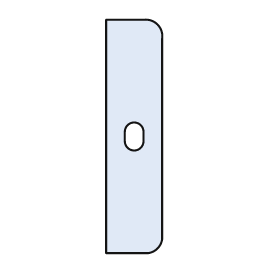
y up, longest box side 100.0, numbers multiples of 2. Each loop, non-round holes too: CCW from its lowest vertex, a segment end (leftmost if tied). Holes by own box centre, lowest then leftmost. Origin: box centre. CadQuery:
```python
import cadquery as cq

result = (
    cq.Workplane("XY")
    .moveTo(-12.0, -50.0)
    .lineTo(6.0, -50.0)
    .threePointArc((10.0, -48.0), (12.0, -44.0))
    .lineTo(12.0, 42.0)
    .threePointArc((10.0, 48.0), (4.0, 50.0))
    .lineTo(-12.0, 50.0)
    .close()
    .moveTo(-4.0, -2.0)
    .threePointArc((0.0, -6.0), (4.0, -2.0))
    .lineTo(4.0, 2.0)
    .threePointArc((0.0, 6.0), (-4.0, 2.0))
    .close()
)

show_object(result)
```